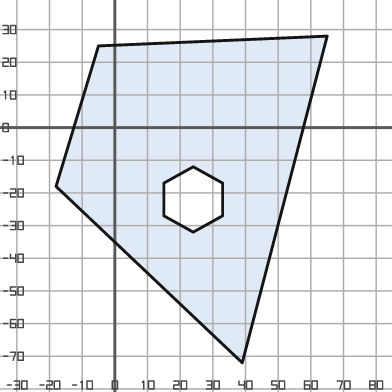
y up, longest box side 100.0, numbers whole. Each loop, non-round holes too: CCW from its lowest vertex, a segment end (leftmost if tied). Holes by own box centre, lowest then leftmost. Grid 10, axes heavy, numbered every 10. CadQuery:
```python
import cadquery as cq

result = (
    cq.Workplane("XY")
    .moveTo(39.0, -72.0)
    .lineTo(65.0, 28.0)
    .lineTo(-5.0, 25.0)
    .lineTo(-18.0, -18.0)
    .close()
    .moveTo(24.0, -32.0)
    .lineTo(33.0, -27.0)
    .lineTo(33.0, -17.0)
    .lineTo(24.0, -12.0)
    .lineTo(15.0, -17.0)
    .lineTo(15.0, -27.0)
    .close()
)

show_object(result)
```